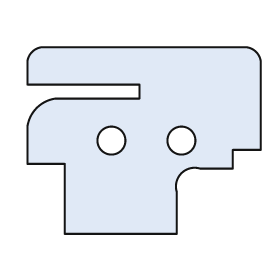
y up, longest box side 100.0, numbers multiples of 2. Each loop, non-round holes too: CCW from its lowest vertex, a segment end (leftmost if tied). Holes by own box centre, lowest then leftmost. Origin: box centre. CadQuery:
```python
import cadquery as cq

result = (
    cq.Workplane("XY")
    .moveTo(-34.0, -40.0)
    .lineTo(14.0, -40.0)
    .lineTo(14.0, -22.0)
    .threePointArc((16.0, -14.0), (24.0, -12.0))
    .lineTo(38.0, -12.0)
    .lineTo(38.0, -4.0)
    .lineTo(50.0, -4.0)
    .lineTo(50.0, 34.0)
    .threePointArc((48.0, 38.0), (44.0, 40.0))
    .lineTo(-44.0, 40.0)
    .threePointArc((-48.0, 38.0), (-50.0, 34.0))
    .lineTo(-50.0, 24.0)
    .lineTo(-2.0, 24.0)
    .lineTo(-2.0, 18.0)
    .lineTo(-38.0, 18.0)
    .threePointArc((-46.0, 14.0), (-50.0, 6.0))
    .lineTo(-50.0, -10.0)
    .lineTo(-34.0, -10.0)
    .close()
    .moveTo(-14.0, 0.0)
    .circle(6.0)
    .moveTo(16.0, 0.0)
    .circle(6.0)
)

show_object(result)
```